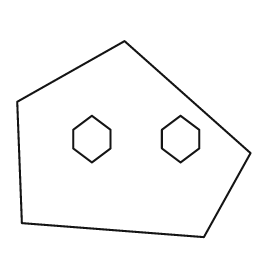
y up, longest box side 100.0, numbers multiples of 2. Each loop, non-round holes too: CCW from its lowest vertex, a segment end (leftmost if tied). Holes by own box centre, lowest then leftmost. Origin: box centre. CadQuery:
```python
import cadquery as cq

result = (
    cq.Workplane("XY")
    .moveTo(30.0, -42.0)
    .lineTo(50.0, -6.0)
    .lineTo(-4.0, 42.0)
    .lineTo(-50.0, 16.0)
    .lineTo(-48.0, -36.0)
    .close()
    .moveTo(-18.0, -10.0)
    .lineTo(-10.0, -4.0)
    .lineTo(-10.0, 4.0)
    .lineTo(-18.0, 10.0)
    .lineTo(-26.0, 4.0)
    .lineTo(-26.0, -4.0)
    .close()
    .moveTo(20.0, -10.0)
    .lineTo(28.0, -4.0)
    .lineTo(28.0, 4.0)
    .lineTo(20.0, 10.0)
    .lineTo(12.0, 4.0)
    .lineTo(12.0, -4.0)
    .close()
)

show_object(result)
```